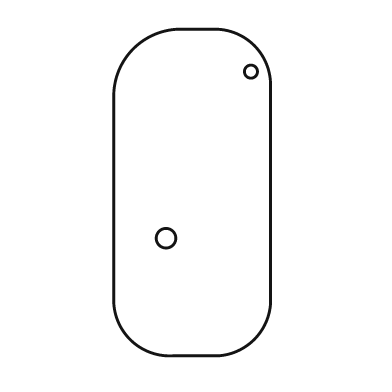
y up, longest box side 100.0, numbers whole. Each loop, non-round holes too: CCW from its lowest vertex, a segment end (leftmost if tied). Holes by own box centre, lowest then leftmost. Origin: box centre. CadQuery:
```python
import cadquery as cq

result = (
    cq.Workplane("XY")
    .moveTo(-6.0, -50.0)
    .lineTo(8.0, -50.0)
    .threePointArc((19.0, -45.0), (24.0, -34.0))
    .lineTo(24.0, 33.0)
    .threePointArc((19.0, 45.0), (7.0, 50.0))
    .lineTo(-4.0, 50.0)
    .threePointArc((-18.0, 44.0), (-24.0, 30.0))
    .lineTo(-24.0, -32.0)
    .threePointArc((-19.0, -45.0), (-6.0, -50.0))
    .close()
    .moveTo(-8.0, -14.0)
    .circle(3.0)
    .moveTo(18.0, 37.0)
    .circle(2.0)
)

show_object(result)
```